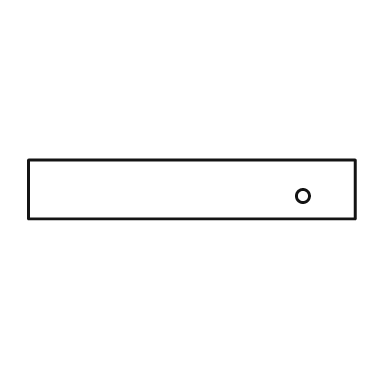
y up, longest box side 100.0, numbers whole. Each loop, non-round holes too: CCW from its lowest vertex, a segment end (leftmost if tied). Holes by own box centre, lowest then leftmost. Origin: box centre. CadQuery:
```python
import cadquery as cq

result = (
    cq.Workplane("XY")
    .moveTo(-50.0, -9.0)
    .lineTo(50.0, -9.0)
    .lineTo(50.0, 9.0)
    .lineTo(-50.0, 9.0)
    .close()
    .moveTo(34.0, -2.0)
    .circle(2.0)
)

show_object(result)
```